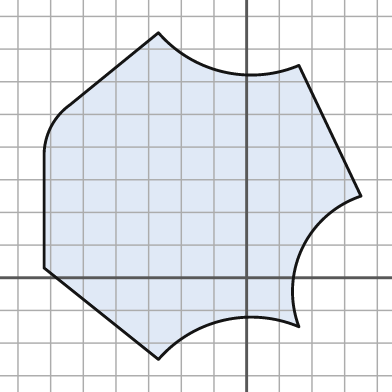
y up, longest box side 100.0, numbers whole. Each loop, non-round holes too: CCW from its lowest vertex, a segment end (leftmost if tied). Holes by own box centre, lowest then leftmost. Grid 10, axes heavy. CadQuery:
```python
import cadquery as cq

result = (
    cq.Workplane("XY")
    .moveTo(-27.0, -25.0)
    .threePointArc((-7.0, -13.0), (16.0, -15.0))
    .threePointArc((17.0, 9.0), (35.0, 25.0))
    .lineTo(16.0, 65.0)
    .threePointArc((-7.0, 63.0), (-27.0, 75.0))
    .lineTo(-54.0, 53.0)
    .threePointArc((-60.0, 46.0), (-62.0, 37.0))
    .lineTo(-62.0, 3.0)
    .close()
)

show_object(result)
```